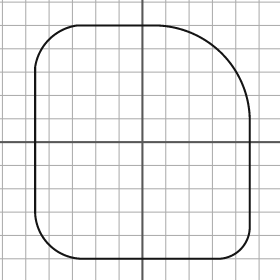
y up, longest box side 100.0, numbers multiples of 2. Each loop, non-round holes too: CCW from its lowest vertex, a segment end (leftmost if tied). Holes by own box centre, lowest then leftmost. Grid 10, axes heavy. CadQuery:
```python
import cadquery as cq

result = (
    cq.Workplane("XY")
    .moveTo(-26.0, -50.0)
    .lineTo(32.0, -50.0)
    .threePointArc((42.0, -46.0), (46.0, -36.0))
    .lineTo(46.0, 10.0)
    .threePointArc((34.0, 38.0), (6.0, 50.0))
    .lineTo(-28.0, 50.0)
    .threePointArc((-40.0, 44.0), (-46.0, 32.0))
    .lineTo(-46.0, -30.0)
    .threePointArc((-40.0, -44.0), (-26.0, -50.0))
    .close()
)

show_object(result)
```